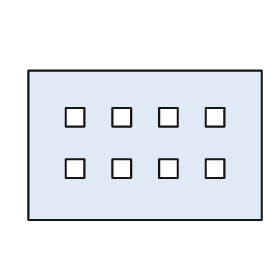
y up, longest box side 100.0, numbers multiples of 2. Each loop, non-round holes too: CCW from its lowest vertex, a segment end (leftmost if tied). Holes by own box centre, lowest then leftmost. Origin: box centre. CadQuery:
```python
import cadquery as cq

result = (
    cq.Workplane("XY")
    .moveTo(-50.0, -32.0)
    .lineTo(50.0, -32.0)
    .lineTo(50.0, 32.0)
    .lineTo(-50.0, 32.0)
    .close()
    .moveTo(-34.0, -14.0)
    .lineTo(-26.0, -14.0)
    .lineTo(-26.0, -6.0)
    .lineTo(-34.0, -6.0)
    .close()
    .moveTo(-14.0, -14.0)
    .lineTo(-6.0, -14.0)
    .lineTo(-6.0, -6.0)
    .lineTo(-14.0, -6.0)
    .close()
    .moveTo(6.0, -14.0)
    .lineTo(14.0, -14.0)
    .lineTo(14.0, -6.0)
    .lineTo(6.0, -6.0)
    .close()
    .moveTo(26.0, -14.0)
    .lineTo(34.0, -14.0)
    .lineTo(34.0, -6.0)
    .lineTo(26.0, -6.0)
    .close()
    .moveTo(-34.0, 8.0)
    .lineTo(-26.0, 8.0)
    .lineTo(-26.0, 16.0)
    .lineTo(-34.0, 16.0)
    .close()
    .moveTo(-14.0, 8.0)
    .lineTo(-6.0, 8.0)
    .lineTo(-6.0, 16.0)
    .lineTo(-14.0, 16.0)
    .close()
    .moveTo(6.0, 8.0)
    .lineTo(14.0, 8.0)
    .lineTo(14.0, 16.0)
    .lineTo(6.0, 16.0)
    .close()
    .moveTo(26.0, 8.0)
    .lineTo(34.0, 8.0)
    .lineTo(34.0, 16.0)
    .lineTo(26.0, 16.0)
    .close()
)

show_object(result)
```